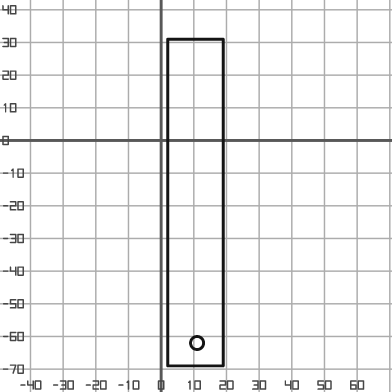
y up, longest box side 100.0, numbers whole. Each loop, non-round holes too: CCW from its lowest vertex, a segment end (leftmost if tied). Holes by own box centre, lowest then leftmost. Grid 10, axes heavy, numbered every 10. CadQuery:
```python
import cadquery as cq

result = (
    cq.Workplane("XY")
    .moveTo(2.0, -69.0)
    .lineTo(19.0, -69.0)
    .lineTo(19.0, 31.0)
    .lineTo(2.0, 31.0)
    .close()
    .moveTo(11.0, -62.0)
    .circle(2.0)
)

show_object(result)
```